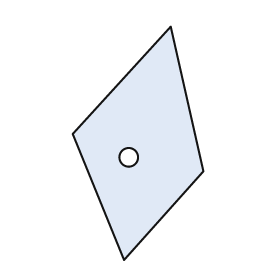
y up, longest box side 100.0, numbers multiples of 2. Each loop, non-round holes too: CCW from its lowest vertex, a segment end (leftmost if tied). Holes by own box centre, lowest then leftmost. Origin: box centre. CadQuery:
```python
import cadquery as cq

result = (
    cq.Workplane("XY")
    .moveTo(-6.0, -50.0)
    .lineTo(28.0, -12.0)
    .lineTo(14.0, 50.0)
    .lineTo(-28.0, 4.0)
    .close()
    .moveTo(-4.0, -6.0)
    .circle(4.0)
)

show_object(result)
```